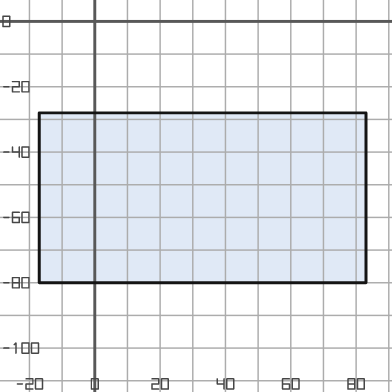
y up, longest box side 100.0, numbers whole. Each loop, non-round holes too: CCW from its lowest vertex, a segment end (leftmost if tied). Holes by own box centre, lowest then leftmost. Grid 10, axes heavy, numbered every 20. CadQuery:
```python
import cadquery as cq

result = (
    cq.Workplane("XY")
    .moveTo(-17.0, -80.0)
    .lineTo(83.0, -80.0)
    .lineTo(83.0, -28.0)
    .lineTo(-17.0, -28.0)
    .close()
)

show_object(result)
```